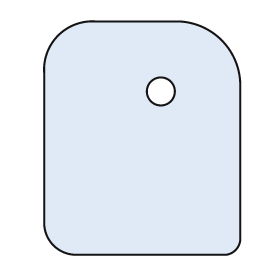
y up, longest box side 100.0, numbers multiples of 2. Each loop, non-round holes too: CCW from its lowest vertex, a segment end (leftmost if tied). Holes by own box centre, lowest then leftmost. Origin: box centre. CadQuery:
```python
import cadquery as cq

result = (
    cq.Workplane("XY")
    .moveTo(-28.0, -50.0)
    .lineTo(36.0, -50.0)
    .threePointArc((40.0, -48.0), (42.0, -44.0))
    .lineTo(42.0, 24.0)
    .threePointArc((34.0, 42.0), (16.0, 50.0))
    .lineTo(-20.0, 50.0)
    .threePointArc((-36.0, 44.0), (-42.0, 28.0))
    .lineTo(-42.0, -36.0)
    .threePointArc((-38.0, -46.0), (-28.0, -50.0))
    .close()
    .moveTo(8.0, 20.0)
    .circle(6.0)
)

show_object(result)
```